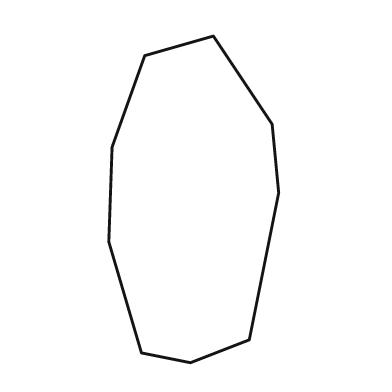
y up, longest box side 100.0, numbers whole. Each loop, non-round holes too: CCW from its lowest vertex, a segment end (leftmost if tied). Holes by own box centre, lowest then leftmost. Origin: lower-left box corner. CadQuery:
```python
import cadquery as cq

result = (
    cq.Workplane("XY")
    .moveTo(25.0, 0.0)
    .lineTo(43.0, 7.0)
    .lineTo(52.0, 52.0)
    .lineTo(50.0, 73.0)
    .lineTo(32.0, 100.0)
    .lineTo(11.0, 94.0)
    .lineTo(1.0, 66.0)
    .lineTo(0.0, 37.0)
    .lineTo(10.0, 3.0)
    .close()
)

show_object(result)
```